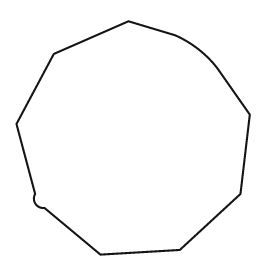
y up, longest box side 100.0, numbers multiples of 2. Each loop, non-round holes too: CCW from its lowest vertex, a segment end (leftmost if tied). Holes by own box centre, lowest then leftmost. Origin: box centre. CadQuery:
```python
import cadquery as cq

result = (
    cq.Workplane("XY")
    .moveTo(-14.0, -50.0)
    .lineTo(20.0, -48.0)
    .lineTo(46.0, -24.0)
    .lineTo(50.0, 10.0)
    .lineTo(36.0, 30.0)
    .threePointArc((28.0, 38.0), (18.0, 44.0))
    .lineTo(-2.0, 50.0)
    .lineTo(-34.0, 36.0)
    .lineTo(-50.0, 6.0)
    .lineTo(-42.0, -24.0)
    .threePointArc((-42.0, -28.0), (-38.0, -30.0))
    .close()
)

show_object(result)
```